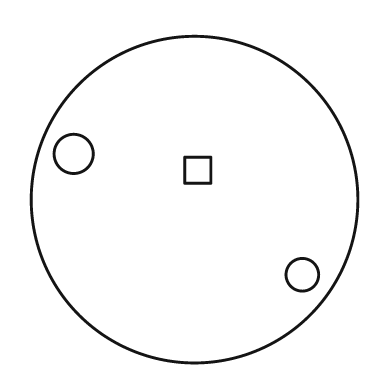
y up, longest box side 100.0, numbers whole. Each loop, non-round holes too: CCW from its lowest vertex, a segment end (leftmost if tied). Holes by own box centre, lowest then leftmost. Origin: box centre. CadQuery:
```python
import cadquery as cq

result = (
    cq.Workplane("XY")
    .moveTo(0.0, 0.0)
    .circle(50.0)
    .moveTo(33.0, -23.0)
    .circle(5.0)
    .moveTo(-3.0, 5.0)
    .lineTo(5.0, 5.0)
    .lineTo(5.0, 13.0)
    .lineTo(-3.0, 13.0)
    .close()
    .moveTo(-37.0, 14.0)
    .circle(6.0)
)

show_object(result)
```